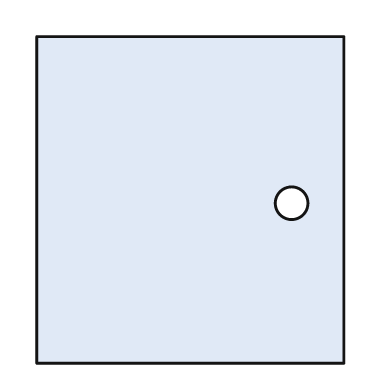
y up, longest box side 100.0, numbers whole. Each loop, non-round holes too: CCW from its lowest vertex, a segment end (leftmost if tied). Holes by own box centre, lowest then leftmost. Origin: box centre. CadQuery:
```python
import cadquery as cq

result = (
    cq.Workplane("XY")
    .moveTo(-47.0, -50.0)
    .lineTo(47.0, -50.0)
    .lineTo(47.0, 50.0)
    .lineTo(-47.0, 50.0)
    .close()
    .moveTo(31.0, -1.0)
    .circle(5.0)
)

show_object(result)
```